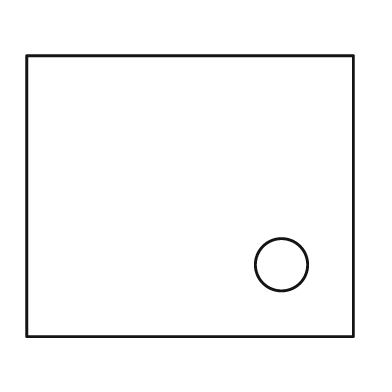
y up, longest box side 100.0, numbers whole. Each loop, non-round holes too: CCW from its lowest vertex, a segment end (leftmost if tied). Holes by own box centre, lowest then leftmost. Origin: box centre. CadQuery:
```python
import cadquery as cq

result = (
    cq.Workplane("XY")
    .moveTo(-50.0, -43.0)
    .lineTo(50.0, -43.0)
    .lineTo(50.0, 43.0)
    .lineTo(-50.0, 43.0)
    .close()
    .moveTo(28.0, -21.0)
    .circle(8.0)
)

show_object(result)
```